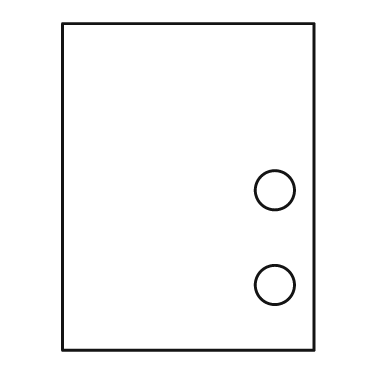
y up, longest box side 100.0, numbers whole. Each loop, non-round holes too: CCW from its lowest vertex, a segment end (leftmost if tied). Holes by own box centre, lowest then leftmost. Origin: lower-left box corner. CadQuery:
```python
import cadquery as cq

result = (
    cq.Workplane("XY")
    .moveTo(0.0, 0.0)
    .lineTo(77.0, 0.0)
    .lineTo(77.0, 100.0)
    .lineTo(0.0, 100.0)
    .close()
    .moveTo(65.0, 20.0)
    .circle(6.0)
    .moveTo(65.0, 49.0)
    .circle(6.0)
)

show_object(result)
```